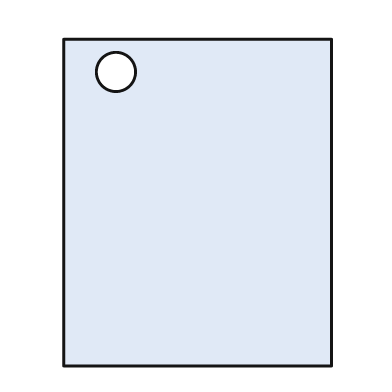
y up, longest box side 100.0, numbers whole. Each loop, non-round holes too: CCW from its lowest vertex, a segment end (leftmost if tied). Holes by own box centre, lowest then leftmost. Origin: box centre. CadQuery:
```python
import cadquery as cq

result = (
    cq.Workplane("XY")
    .moveTo(-41.0, -50.0)
    .lineTo(41.0, -50.0)
    .lineTo(41.0, 50.0)
    .lineTo(-41.0, 50.0)
    .close()
    .moveTo(-25.0, 40.0)
    .circle(6.0)
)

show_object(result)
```